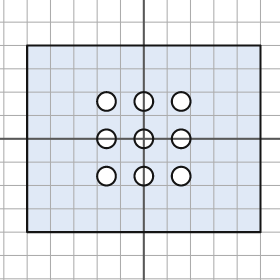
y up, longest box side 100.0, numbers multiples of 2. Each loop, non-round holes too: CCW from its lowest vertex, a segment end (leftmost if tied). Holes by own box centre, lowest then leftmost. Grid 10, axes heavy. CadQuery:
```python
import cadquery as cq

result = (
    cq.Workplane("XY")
    .moveTo(-50.0, -40.0)
    .lineTo(50.0, -40.0)
    .lineTo(50.0, 40.0)
    .lineTo(-50.0, 40.0)
    .close()
    .moveTo(-16.0, -16.0)
    .circle(4.0)
    .moveTo(0.0, -16.0)
    .circle(4.0)
    .moveTo(16.0, -16.0)
    .circle(4.0)
    .moveTo(-16.0, 0.0)
    .circle(4.0)
    .moveTo(0.0, 0.0)
    .circle(4.0)
    .moveTo(16.0, 0.0)
    .circle(4.0)
    .moveTo(-16.0, 16.0)
    .circle(4.0)
    .moveTo(0.0, 16.0)
    .circle(4.0)
    .moveTo(16.0, 16.0)
    .circle(4.0)
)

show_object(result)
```